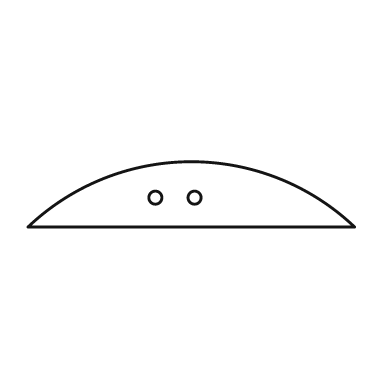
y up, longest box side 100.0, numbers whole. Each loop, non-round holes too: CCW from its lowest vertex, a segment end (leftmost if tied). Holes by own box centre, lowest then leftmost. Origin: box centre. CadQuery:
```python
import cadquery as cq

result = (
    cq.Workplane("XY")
    .moveTo(-50.0, -10.0)
    .lineTo(50.0, -10.0)
    .threePointArc((0.0, 10.0), (-50.0, -10.0))
    .close()
    .moveTo(-11.0, -1.0)
    .circle(2.0)
    .moveTo(1.0, -1.0)
    .circle(2.0)
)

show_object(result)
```